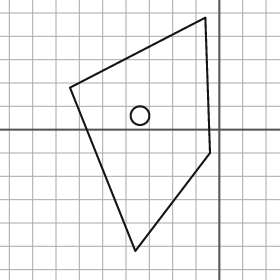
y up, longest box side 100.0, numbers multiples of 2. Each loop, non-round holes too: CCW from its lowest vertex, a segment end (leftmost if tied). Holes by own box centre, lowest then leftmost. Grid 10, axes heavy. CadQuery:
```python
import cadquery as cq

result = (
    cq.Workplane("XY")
    .moveTo(-36.0, -52.0)
    .lineTo(-4.0, -10.0)
    .lineTo(-6.0, 48.0)
    .lineTo(-64.0, 18.0)
    .close()
    .moveTo(-34.0, 6.0)
    .circle(4.0)
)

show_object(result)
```